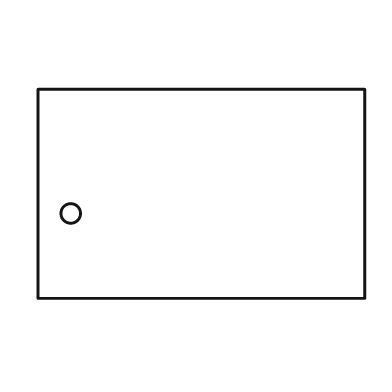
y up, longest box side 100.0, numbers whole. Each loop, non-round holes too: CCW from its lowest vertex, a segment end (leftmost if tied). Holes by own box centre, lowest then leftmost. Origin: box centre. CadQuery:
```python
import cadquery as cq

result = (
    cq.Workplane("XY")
    .moveTo(-50.0, -32.0)
    .lineTo(50.0, -32.0)
    .lineTo(50.0, 32.0)
    .lineTo(-50.0, 32.0)
    .close()
    .moveTo(-40.0, -6.0)
    .circle(3.0)
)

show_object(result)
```